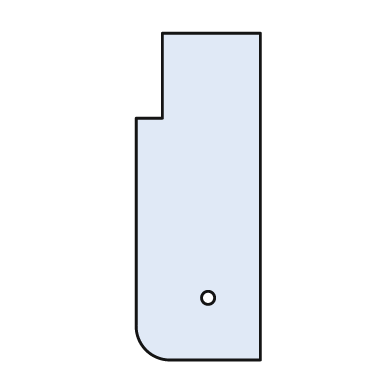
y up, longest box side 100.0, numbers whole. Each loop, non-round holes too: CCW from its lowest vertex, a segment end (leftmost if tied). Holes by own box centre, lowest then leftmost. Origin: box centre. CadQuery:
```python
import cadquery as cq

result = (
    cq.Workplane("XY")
    .moveTo(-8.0, -50.0)
    .lineTo(19.0, -50.0)
    .lineTo(19.0, 50.0)
    .lineTo(-11.0, 50.0)
    .lineTo(-11.0, 24.0)
    .lineTo(-19.0, 24.0)
    .lineTo(-19.0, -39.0)
    .threePointArc((-16.0, -47.0), (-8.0, -50.0))
    .close()
    .moveTo(3.0, -31.0)
    .circle(2.0)
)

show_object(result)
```